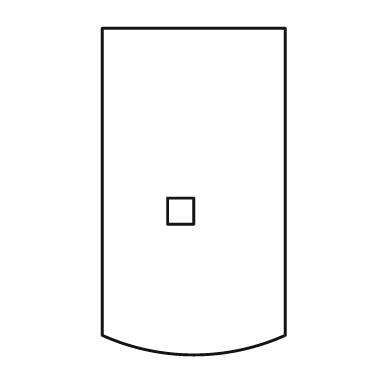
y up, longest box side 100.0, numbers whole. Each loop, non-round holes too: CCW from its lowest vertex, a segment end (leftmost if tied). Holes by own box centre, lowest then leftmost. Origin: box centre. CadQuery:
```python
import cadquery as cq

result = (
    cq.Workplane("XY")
    .moveTo(-28.0, -44.0)
    .threePointArc((0.0, -50.0), (28.0, -44.0))
    .lineTo(28.0, 50.0)
    .lineTo(-28.0, 50.0)
    .close()
    .moveTo(-8.0, -10.0)
    .lineTo(0.0, -10.0)
    .lineTo(0.0, -2.0)
    .lineTo(-8.0, -2.0)
    .close()
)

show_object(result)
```